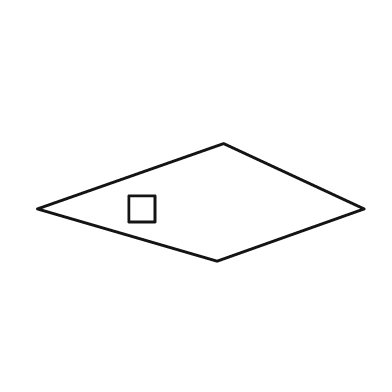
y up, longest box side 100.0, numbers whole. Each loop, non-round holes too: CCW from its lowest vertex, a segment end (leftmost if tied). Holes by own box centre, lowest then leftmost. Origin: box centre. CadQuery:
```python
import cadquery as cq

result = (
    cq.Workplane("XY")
    .moveTo(5.0, -18.0)
    .lineTo(50.0, -2.0)
    .lineTo(7.0, 18.0)
    .lineTo(-50.0, -2.0)
    .close()
    .moveTo(-22.0, -6.0)
    .lineTo(-14.0, -6.0)
    .lineTo(-14.0, 2.0)
    .lineTo(-22.0, 2.0)
    .close()
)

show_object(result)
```